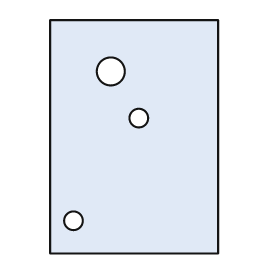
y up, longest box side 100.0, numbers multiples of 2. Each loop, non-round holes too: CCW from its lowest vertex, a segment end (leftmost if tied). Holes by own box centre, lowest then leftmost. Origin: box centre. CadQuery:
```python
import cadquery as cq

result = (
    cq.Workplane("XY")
    .moveTo(-36.0, -50.0)
    .lineTo(36.0, -50.0)
    .lineTo(36.0, 50.0)
    .lineTo(-36.0, 50.0)
    .close()
    .moveTo(-26.0, -36.0)
    .circle(4.0)
    .moveTo(2.0, 8.0)
    .circle(4.0)
    .moveTo(-10.0, 28.0)
    .circle(6.0)
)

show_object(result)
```